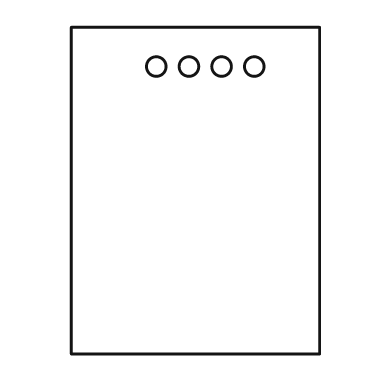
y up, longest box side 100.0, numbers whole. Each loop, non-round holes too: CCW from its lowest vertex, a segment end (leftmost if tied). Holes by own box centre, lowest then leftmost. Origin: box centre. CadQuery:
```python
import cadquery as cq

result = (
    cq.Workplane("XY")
    .moveTo(-38.0, -50.0)
    .lineTo(38.0, -50.0)
    .lineTo(38.0, 50.0)
    .lineTo(-38.0, 50.0)
    .close()
    .moveTo(-12.0, 38.0)
    .circle(3.0)
    .moveTo(-2.0, 38.0)
    .circle(3.0)
    .moveTo(8.0, 38.0)
    .circle(3.0)
    .moveTo(18.0, 38.0)
    .circle(3.0)
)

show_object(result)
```